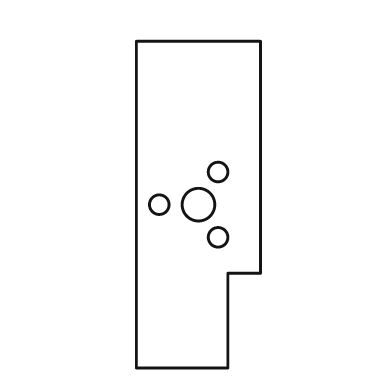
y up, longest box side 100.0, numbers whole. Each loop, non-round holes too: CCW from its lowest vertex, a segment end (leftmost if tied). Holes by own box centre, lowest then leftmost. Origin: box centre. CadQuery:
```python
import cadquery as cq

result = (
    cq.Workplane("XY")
    .moveTo(-19.0, -50.0)
    .lineTo(9.0, -50.0)
    .lineTo(9.0, -21.0)
    .lineTo(19.0, -21.0)
    .lineTo(19.0, 50.0)
    .lineTo(-19.0, 50.0)
    .close()
    .moveTo(6.0, -10.0)
    .circle(3.0)
    .moveTo(-12.0, 0.0)
    .circle(3.0)
    .moveTo(0.0, 0.0)
    .circle(5.0)
    .moveTo(6.0, 10.0)
    .circle(3.0)
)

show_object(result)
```